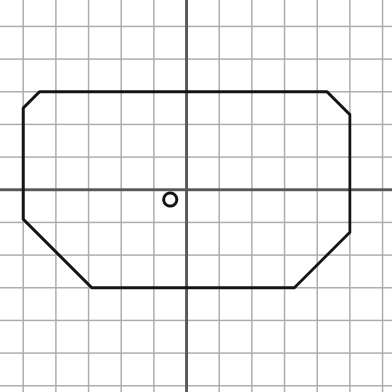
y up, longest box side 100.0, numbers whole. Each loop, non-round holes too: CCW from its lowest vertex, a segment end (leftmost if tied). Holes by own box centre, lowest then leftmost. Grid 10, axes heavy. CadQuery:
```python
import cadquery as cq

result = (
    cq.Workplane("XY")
    .moveTo(-29.0, -30.0)
    .lineTo(33.0, -30.0)
    .lineTo(50.0, -13.0)
    .lineTo(50.0, 23.0)
    .lineTo(43.0, 30.0)
    .lineTo(-45.0, 30.0)
    .lineTo(-50.0, 25.0)
    .lineTo(-50.0, -9.0)
    .close()
    .moveTo(-5.0, -3.0)
    .circle(2.0)
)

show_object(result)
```